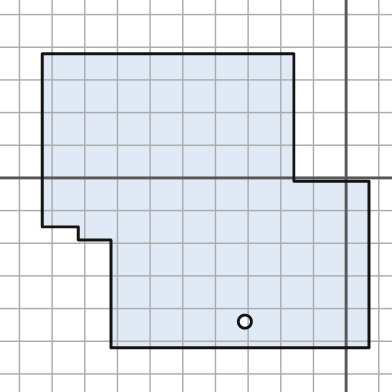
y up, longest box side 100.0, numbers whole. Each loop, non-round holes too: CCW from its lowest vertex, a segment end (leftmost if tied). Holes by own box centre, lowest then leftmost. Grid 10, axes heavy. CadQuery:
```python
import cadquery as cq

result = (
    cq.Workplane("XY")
    .moveTo(-72.0, -52.0)
    .lineTo(7.0, -52.0)
    .lineTo(7.0, -1.0)
    .lineTo(-16.0, -1.0)
    .lineTo(-16.0, 38.0)
    .lineTo(-93.0, 38.0)
    .lineTo(-93.0, -15.0)
    .lineTo(-82.0, -15.0)
    .lineTo(-82.0, -19.0)
    .lineTo(-72.0, -19.0)
    .close()
    .moveTo(-31.0, -44.0)
    .circle(2.0)
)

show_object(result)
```